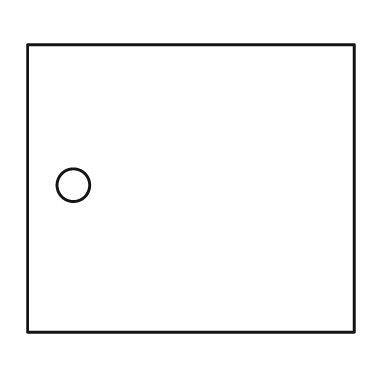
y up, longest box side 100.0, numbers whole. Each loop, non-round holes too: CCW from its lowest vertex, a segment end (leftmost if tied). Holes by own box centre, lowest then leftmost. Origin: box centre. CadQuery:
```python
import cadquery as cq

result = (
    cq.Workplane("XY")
    .moveTo(-50.0, -44.0)
    .lineTo(50.0, -44.0)
    .lineTo(50.0, 44.0)
    .lineTo(-50.0, 44.0)
    .close()
    .moveTo(-36.0, 1.0)
    .circle(5.0)
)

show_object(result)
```